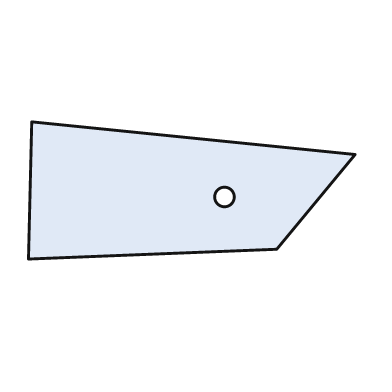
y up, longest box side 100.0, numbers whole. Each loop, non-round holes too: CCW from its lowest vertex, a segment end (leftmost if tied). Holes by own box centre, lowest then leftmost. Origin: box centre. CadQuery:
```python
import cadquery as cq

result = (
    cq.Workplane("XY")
    .moveTo(-50.0, -21.0)
    .lineTo(26.0, -18.0)
    .lineTo(50.0, 11.0)
    .lineTo(-49.0, 21.0)
    .close()
    .moveTo(10.0, -2.0)
    .circle(3.0)
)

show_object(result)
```